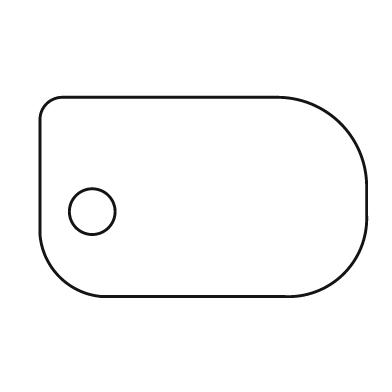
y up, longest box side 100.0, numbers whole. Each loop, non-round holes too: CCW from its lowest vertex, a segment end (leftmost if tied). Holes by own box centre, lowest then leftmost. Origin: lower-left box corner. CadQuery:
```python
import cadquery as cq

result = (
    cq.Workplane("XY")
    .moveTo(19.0, 0.0)
    .lineTo(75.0, 0.0)
    .threePointArc((93.0, 7.0), (100.0, 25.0))
    .lineTo(100.0, 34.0)
    .threePointArc((92.0, 53.0), (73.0, 61.0))
    .lineTo(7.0, 61.0)
    .threePointArc((2.0, 59.0), (0.0, 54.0))
    .lineTo(0.0, 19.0)
    .threePointArc((6.0, 6.0), (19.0, 0.0))
    .close()
    .moveTo(16.0, 26.0)
    .circle(7.0)
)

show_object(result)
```